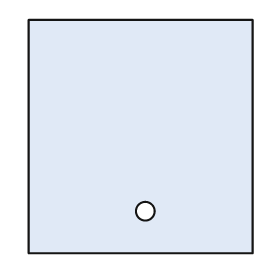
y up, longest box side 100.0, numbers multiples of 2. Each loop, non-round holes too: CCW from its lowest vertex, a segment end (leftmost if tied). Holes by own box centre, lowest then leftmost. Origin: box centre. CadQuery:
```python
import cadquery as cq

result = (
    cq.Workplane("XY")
    .moveTo(-48.0, -50.0)
    .lineTo(48.0, -50.0)
    .lineTo(48.0, 50.0)
    .lineTo(-48.0, 50.0)
    .close()
    .moveTo(2.0, -32.0)
    .circle(4.0)
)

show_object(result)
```